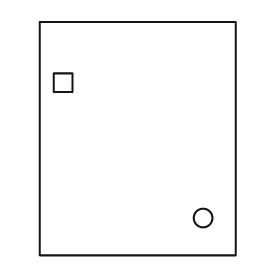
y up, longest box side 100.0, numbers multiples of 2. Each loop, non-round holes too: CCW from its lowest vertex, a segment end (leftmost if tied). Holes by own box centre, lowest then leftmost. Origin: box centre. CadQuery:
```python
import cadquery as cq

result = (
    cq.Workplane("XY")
    .moveTo(-42.0, -50.0)
    .lineTo(42.0, -50.0)
    .lineTo(42.0, 50.0)
    .lineTo(-42.0, 50.0)
    .close()
    .moveTo(28.0, -34.0)
    .circle(4.0)
    .moveTo(-36.0, 20.0)
    .lineTo(-28.0, 20.0)
    .lineTo(-28.0, 28.0)
    .lineTo(-36.0, 28.0)
    .close()
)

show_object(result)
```